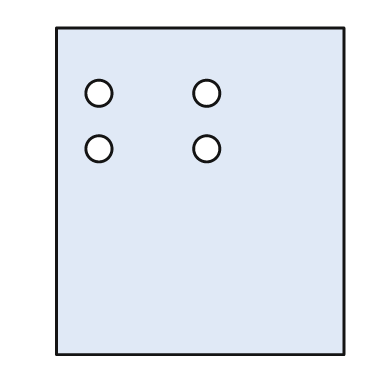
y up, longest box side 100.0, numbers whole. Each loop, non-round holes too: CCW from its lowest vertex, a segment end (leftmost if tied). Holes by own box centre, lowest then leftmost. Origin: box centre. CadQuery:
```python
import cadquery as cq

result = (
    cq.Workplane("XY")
    .moveTo(-44.0, -50.0)
    .lineTo(44.0, -50.0)
    .lineTo(44.0, 50.0)
    .lineTo(-44.0, 50.0)
    .close()
    .moveTo(-31.0, 13.0)
    .circle(4.0)
    .moveTo(2.0, 13.0)
    .circle(4.0)
    .moveTo(-31.0, 30.0)
    .circle(4.0)
    .moveTo(2.0, 30.0)
    .circle(4.0)
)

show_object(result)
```